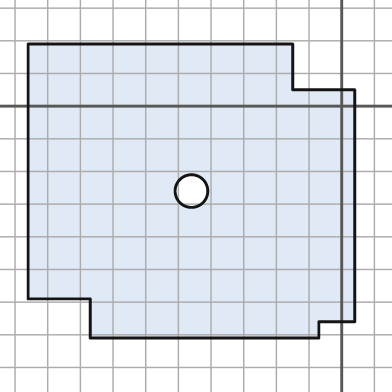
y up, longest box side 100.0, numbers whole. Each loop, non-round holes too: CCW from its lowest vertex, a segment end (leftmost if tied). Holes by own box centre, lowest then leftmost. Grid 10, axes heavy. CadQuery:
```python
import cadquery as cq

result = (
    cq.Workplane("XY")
    .moveTo(-77.0, -71.0)
    .lineTo(-7.0, -71.0)
    .lineTo(-7.0, -66.0)
    .lineTo(4.0, -66.0)
    .lineTo(4.0, 5.0)
    .lineTo(-15.0, 5.0)
    .lineTo(-15.0, 19.0)
    .lineTo(-96.0, 19.0)
    .lineTo(-96.0, -59.0)
    .lineTo(-77.0, -59.0)
    .close()
    .moveTo(-46.0, -26.0)
    .circle(5.0)
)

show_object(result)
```